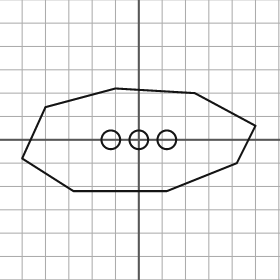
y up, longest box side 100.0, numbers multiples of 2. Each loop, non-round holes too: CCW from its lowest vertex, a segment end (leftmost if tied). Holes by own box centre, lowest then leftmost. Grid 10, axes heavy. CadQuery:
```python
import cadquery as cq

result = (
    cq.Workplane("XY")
    .moveTo(-28.0, -22.0)
    .lineTo(12.0, -22.0)
    .lineTo(42.0, -10.0)
    .lineTo(50.0, 6.0)
    .lineTo(24.0, 20.0)
    .lineTo(-10.0, 22.0)
    .lineTo(-40.0, 14.0)
    .lineTo(-50.0, -8.0)
    .close()
    .moveTo(-12.0, 0.0)
    .circle(4.0)
    .moveTo(0.0, 0.0)
    .circle(4.0)
    .moveTo(12.0, 0.0)
    .circle(4.0)
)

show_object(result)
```